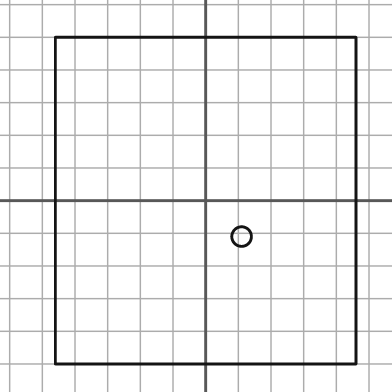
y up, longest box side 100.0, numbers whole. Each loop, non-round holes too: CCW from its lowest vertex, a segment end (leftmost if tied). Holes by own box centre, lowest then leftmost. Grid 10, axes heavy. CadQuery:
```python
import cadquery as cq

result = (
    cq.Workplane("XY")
    .moveTo(-46.0, -50.0)
    .lineTo(46.0, -50.0)
    .lineTo(46.0, 50.0)
    .lineTo(-46.0, 50.0)
    .close()
    .moveTo(11.0, -11.0)
    .circle(3.0)
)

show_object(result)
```